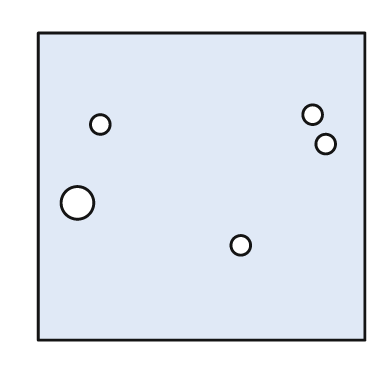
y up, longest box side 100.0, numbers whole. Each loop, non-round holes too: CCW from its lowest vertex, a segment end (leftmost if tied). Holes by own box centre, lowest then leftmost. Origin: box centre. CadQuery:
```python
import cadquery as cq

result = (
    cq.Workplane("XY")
    .moveTo(-50.0, -47.0)
    .lineTo(50.0, -47.0)
    .lineTo(50.0, 47.0)
    .lineTo(-50.0, 47.0)
    .close()
    .moveTo(12.0, -18.0)
    .circle(3.0)
    .moveTo(-38.0, -5.0)
    .circle(5.0)
    .moveTo(38.0, 13.0)
    .circle(3.0)
    .moveTo(-31.0, 19.0)
    .circle(3.0)
    .moveTo(34.0, 22.0)
    .circle(3.0)
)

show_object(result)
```